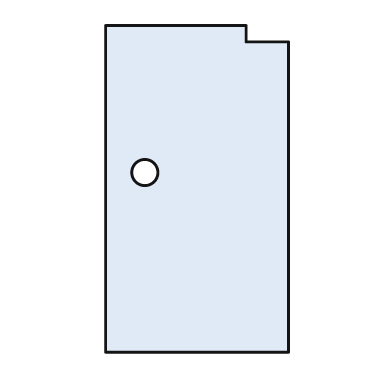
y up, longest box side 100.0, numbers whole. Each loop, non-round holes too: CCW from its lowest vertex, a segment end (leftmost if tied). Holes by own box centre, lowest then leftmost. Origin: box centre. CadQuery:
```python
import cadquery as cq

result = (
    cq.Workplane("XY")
    .moveTo(-28.0, -50.0)
    .lineTo(28.0, -50.0)
    .lineTo(28.0, 45.0)
    .lineTo(15.0, 45.0)
    .lineTo(15.0, 50.0)
    .lineTo(-28.0, 50.0)
    .close()
    .moveTo(-16.0, 5.0)
    .circle(4.0)
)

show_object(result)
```